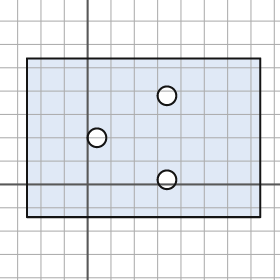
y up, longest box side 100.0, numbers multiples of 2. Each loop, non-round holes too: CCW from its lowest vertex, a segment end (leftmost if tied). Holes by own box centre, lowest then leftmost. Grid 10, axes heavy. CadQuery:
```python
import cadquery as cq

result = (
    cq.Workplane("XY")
    .moveTo(-26.0, -14.0)
    .lineTo(74.0, -14.0)
    .lineTo(74.0, 54.0)
    .lineTo(-26.0, 54.0)
    .close()
    .moveTo(34.0, 2.0)
    .circle(4.0)
    .moveTo(4.0, 20.0)
    .circle(4.0)
    .moveTo(34.0, 38.0)
    .circle(4.0)
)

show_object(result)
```